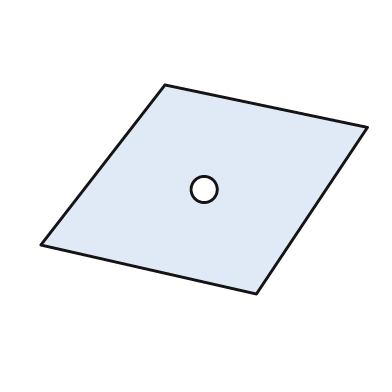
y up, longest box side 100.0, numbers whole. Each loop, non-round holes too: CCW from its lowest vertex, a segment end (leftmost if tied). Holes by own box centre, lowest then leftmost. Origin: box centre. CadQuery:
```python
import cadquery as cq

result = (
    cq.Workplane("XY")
    .moveTo(16.0, -32.0)
    .lineTo(50.0, 19.0)
    .lineTo(-12.0, 32.0)
    .lineTo(-50.0, -17.0)
    .close()
    .moveTo(0.0, 0.0)
    .circle(4.0)
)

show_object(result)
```